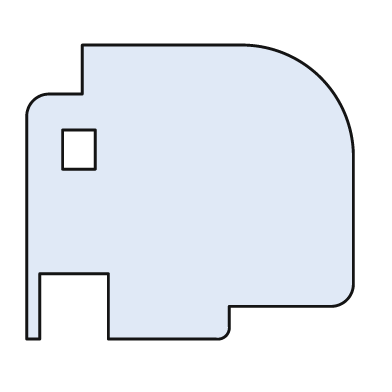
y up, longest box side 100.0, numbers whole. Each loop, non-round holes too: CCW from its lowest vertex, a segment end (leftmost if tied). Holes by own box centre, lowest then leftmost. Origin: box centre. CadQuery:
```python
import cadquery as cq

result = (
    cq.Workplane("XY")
    .moveTo(-50.0, -45.0)
    .lineTo(-46.0, -45.0)
    .lineTo(-46.0, -25.0)
    .lineTo(-25.0, -25.0)
    .lineTo(-25.0, -45.0)
    .lineTo(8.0, -45.0)
    .threePointArc((11.0, -44.0), (12.0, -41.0))
    .lineTo(12.0, -35.0)
    .lineTo(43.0, -35.0)
    .threePointArc((48.0, -33.0), (50.0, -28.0))
    .lineTo(50.0, 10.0)
    .threePointArc((40.0, 35.0), (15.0, 45.0))
    .lineTo(-33.0, 45.0)
    .lineTo(-33.0, 30.0)
    .lineTo(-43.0, 30.0)
    .threePointArc((-48.0, 28.0), (-50.0, 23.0))
    .close()
    .moveTo(-39.0, 7.0)
    .lineTo(-29.0, 7.0)
    .lineTo(-29.0, 19.0)
    .lineTo(-39.0, 19.0)
    .close()
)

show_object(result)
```